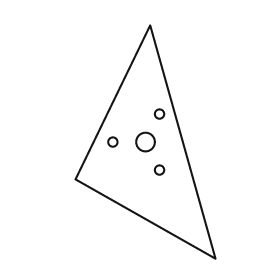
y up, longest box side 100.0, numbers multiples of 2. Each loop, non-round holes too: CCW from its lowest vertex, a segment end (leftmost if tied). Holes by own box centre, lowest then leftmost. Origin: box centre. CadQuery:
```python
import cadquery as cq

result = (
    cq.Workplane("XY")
    .moveTo(30.0, -50.0)
    .lineTo(2.0, 50.0)
    .lineTo(-30.0, -16.0)
    .close()
    .moveTo(6.0, -12.0)
    .circle(2.0)
    .moveTo(-14.0, 0.0)
    .circle(2.0)
    .moveTo(0.0, 0.0)
    .circle(4.0)
    .moveTo(6.0, 12.0)
    .circle(2.0)
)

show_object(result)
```